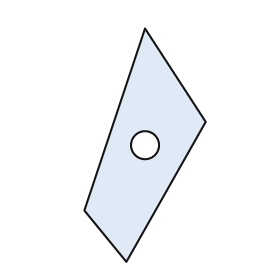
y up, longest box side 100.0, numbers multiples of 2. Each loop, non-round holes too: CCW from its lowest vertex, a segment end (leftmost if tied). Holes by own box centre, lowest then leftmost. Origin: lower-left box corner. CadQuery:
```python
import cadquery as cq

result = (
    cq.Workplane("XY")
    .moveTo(18.0, 0.0)
    .lineTo(52.0, 60.0)
    .lineTo(26.0, 100.0)
    .lineTo(0.0, 22.0)
    .close()
    .moveTo(26.0, 50.0)
    .circle(6.0)
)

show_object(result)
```